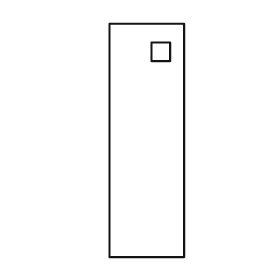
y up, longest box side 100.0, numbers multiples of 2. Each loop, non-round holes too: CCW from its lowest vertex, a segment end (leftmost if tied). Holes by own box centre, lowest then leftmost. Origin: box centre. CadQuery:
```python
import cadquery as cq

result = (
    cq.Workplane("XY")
    .moveTo(-16.0, -50.0)
    .lineTo(16.0, -50.0)
    .lineTo(16.0, 50.0)
    .lineTo(-16.0, 50.0)
    .close()
    .moveTo(2.0, 34.0)
    .lineTo(10.0, 34.0)
    .lineTo(10.0, 42.0)
    .lineTo(2.0, 42.0)
    .close()
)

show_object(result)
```